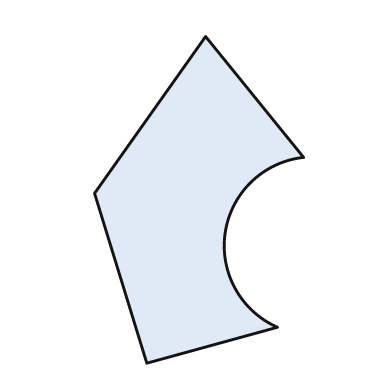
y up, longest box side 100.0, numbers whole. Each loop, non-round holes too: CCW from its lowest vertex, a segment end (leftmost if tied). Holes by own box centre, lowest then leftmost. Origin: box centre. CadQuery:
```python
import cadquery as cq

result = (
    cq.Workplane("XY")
    .moveTo(-16.0, -50.0)
    .lineTo(24.0, -39.0)
    .threePointArc((8.0, -10.0), (32.0, 13.0))
    .lineTo(2.0, 50.0)
    .lineTo(-32.0, 2.0)
    .close()
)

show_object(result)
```